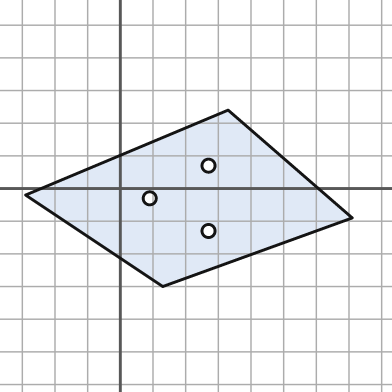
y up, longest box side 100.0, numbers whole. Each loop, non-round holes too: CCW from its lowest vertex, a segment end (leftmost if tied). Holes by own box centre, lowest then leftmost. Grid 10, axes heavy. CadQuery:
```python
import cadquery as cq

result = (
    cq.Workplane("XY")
    .moveTo(13.0, -30.0)
    .lineTo(71.0, -9.0)
    .lineTo(33.0, 24.0)
    .lineTo(-29.0, -2.0)
    .close()
    .moveTo(27.0, -13.0)
    .circle(2.0)
    .moveTo(9.0, -3.0)
    .circle(2.0)
    .moveTo(27.0, 7.0)
    .circle(2.0)
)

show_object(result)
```